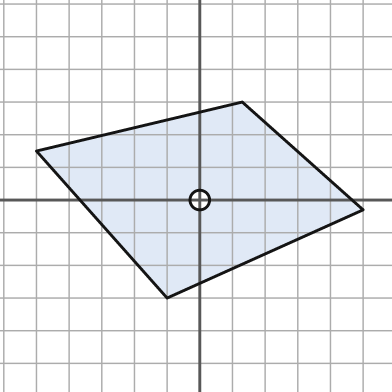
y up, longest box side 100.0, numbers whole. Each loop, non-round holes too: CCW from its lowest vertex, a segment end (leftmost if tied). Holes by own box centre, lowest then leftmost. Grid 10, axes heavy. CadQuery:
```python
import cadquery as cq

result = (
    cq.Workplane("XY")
    .moveTo(-10.0, -30.0)
    .lineTo(50.0, -3.0)
    .lineTo(13.0, 30.0)
    .lineTo(-50.0, 15.0)
    .close()
    .moveTo(0.0, 0.0)
    .circle(3.0)
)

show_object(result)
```